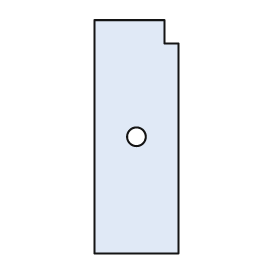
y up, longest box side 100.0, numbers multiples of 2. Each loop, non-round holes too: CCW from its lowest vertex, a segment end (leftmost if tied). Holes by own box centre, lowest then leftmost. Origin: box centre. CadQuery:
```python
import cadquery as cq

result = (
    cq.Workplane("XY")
    .moveTo(-18.0, -50.0)
    .lineTo(18.0, -50.0)
    .lineTo(18.0, 40.0)
    .lineTo(12.0, 40.0)
    .lineTo(12.0, 50.0)
    .lineTo(-18.0, 50.0)
    .close()
    .moveTo(0.0, 0.0)
    .circle(4.0)
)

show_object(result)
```